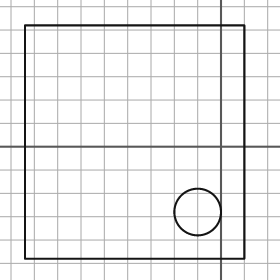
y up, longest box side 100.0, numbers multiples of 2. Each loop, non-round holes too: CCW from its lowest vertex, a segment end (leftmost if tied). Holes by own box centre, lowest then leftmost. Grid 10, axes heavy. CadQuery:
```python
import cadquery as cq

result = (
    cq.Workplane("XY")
    .moveTo(-84.0, -48.0)
    .lineTo(10.0, -48.0)
    .lineTo(10.0, 52.0)
    .lineTo(-84.0, 52.0)
    .close()
    .moveTo(-10.0, -28.0)
    .circle(10.0)
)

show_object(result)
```